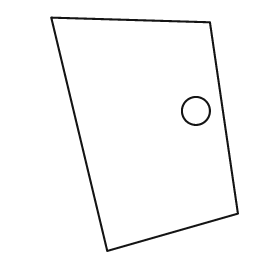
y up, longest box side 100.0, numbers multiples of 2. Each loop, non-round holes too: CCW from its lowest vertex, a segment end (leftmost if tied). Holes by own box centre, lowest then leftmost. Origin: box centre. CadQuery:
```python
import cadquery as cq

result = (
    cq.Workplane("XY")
    .moveTo(-16.0, -50.0)
    .lineTo(40.0, -34.0)
    .lineTo(28.0, 48.0)
    .lineTo(-40.0, 50.0)
    .close()
    .moveTo(22.0, 10.0)
    .circle(6.0)
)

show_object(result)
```